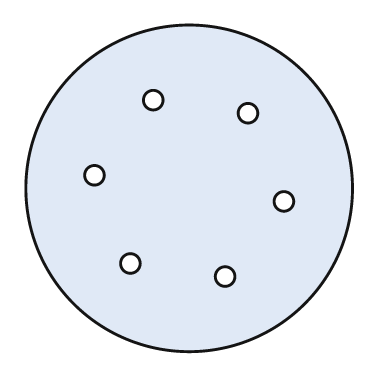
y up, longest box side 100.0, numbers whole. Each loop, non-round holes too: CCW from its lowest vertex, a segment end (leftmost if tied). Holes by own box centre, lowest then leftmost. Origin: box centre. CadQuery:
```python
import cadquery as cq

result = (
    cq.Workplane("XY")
    .moveTo(0.0, 0.0)
    .circle(50.0)
    .moveTo(11.0, -27.0)
    .circle(3.0)
    .moveTo(-18.0, -23.0)
    .circle(3.0)
    .moveTo(29.0, -4.0)
    .circle(3.0)
    .moveTo(-29.0, 4.0)
    .circle(3.0)
    .moveTo(18.0, 23.0)
    .circle(3.0)
    .moveTo(-11.0, 27.0)
    .circle(3.0)
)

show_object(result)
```